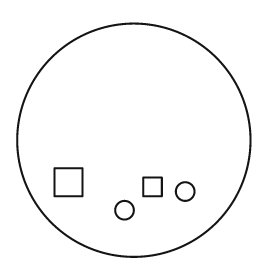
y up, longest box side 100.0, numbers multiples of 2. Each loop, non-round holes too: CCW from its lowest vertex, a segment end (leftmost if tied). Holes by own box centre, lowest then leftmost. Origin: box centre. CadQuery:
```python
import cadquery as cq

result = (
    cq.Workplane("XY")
    .moveTo(0.0, 0.0)
    .circle(50.0)
    .moveTo(-4.0, -30.0)
    .circle(4.0)
    .moveTo(22.0, -22.0)
    .circle(4.0)
    .moveTo(4.0, -24.0)
    .lineTo(12.0, -24.0)
    .lineTo(12.0, -16.0)
    .lineTo(4.0, -16.0)
    .close()
    .moveTo(-34.0, -24.0)
    .lineTo(-22.0, -24.0)
    .lineTo(-22.0, -12.0)
    .lineTo(-34.0, -12.0)
    .close()
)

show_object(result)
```